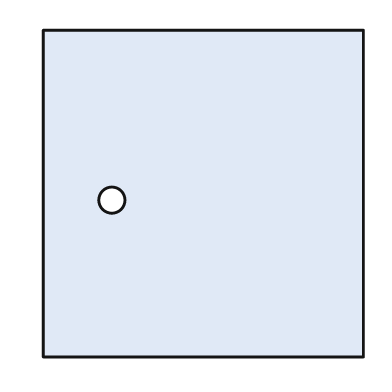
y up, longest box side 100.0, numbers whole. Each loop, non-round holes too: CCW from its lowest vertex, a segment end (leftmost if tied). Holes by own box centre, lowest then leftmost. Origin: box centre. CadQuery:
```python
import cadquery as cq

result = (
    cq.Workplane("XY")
    .moveTo(-49.0, -50.0)
    .lineTo(49.0, -50.0)
    .lineTo(49.0, 50.0)
    .lineTo(-49.0, 50.0)
    .close()
    .moveTo(-28.0, -2.0)
    .circle(4.0)
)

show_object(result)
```